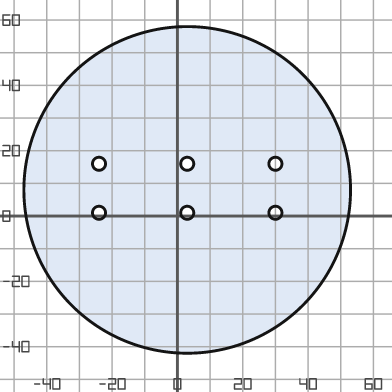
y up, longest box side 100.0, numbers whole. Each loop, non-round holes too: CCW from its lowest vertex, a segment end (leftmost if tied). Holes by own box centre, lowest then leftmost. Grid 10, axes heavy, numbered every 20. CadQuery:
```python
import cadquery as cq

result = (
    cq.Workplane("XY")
    .moveTo(3.0, 8.0)
    .circle(50.0)
    .moveTo(-24.0, 1.0)
    .circle(2.0)
    .moveTo(3.0, 1.0)
    .circle(2.0)
    .moveTo(30.0, 1.0)
    .circle(2.0)
    .moveTo(-24.0, 16.0)
    .circle(2.0)
    .moveTo(3.0, 16.0)
    .circle(2.0)
    .moveTo(30.0, 16.0)
    .circle(2.0)
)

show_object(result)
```